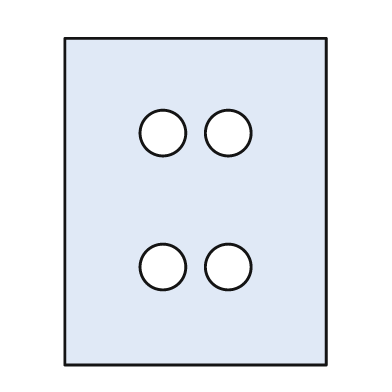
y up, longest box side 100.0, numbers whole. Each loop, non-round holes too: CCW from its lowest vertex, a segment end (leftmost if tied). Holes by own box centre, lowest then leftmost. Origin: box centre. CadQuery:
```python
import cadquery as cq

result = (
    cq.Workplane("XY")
    .moveTo(-40.0, -50.0)
    .lineTo(40.0, -50.0)
    .lineTo(40.0, 50.0)
    .lineTo(-40.0, 50.0)
    .close()
    .moveTo(-10.0, -20.0)
    .circle(7.0)
    .moveTo(10.0, -20.0)
    .circle(7.0)
    .moveTo(-10.0, 21.0)
    .circle(7.0)
    .moveTo(10.0, 21.0)
    .circle(7.0)
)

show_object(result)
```